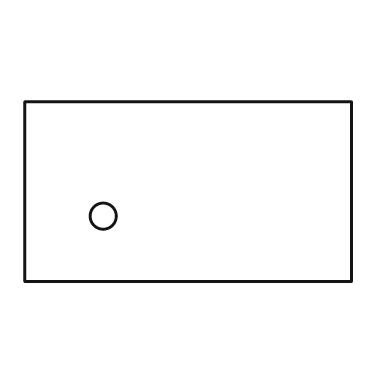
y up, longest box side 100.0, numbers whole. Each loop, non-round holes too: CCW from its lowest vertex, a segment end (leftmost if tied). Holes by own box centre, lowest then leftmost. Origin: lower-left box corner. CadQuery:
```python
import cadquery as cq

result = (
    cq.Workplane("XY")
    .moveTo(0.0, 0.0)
    .lineTo(100.0, 0.0)
    .lineTo(100.0, 55.0)
    .lineTo(0.0, 55.0)
    .close()
    .moveTo(24.0, 20.0)
    .circle(4.0)
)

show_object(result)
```